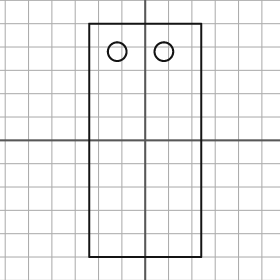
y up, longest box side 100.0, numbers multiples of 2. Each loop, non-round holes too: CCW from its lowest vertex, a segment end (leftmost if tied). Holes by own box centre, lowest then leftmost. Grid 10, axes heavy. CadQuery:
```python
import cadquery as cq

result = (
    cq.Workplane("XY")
    .moveTo(-24.0, -50.0)
    .lineTo(24.0, -50.0)
    .lineTo(24.0, 50.0)
    .lineTo(-24.0, 50.0)
    .close()
    .moveTo(-12.0, 38.0)
    .circle(4.0)
    .moveTo(8.0, 38.0)
    .circle(4.0)
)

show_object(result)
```